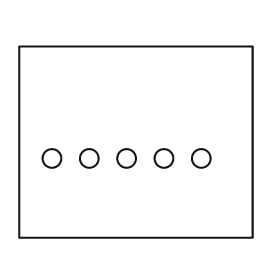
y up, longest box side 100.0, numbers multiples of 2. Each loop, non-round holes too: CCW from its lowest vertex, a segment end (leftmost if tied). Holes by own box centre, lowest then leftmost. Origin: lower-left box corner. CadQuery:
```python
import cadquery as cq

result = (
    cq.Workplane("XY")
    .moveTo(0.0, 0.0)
    .lineTo(100.0, 0.0)
    .lineTo(100.0, 82.0)
    .lineTo(0.0, 82.0)
    .close()
    .moveTo(14.0, 34.0)
    .circle(4.0)
    .moveTo(30.0, 34.0)
    .circle(4.0)
    .moveTo(46.0, 34.0)
    .circle(4.0)
    .moveTo(62.0, 34.0)
    .circle(4.0)
    .moveTo(78.0, 34.0)
    .circle(4.0)
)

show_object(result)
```